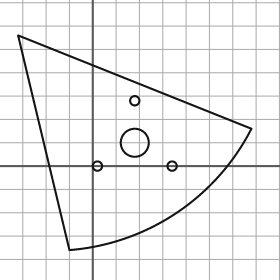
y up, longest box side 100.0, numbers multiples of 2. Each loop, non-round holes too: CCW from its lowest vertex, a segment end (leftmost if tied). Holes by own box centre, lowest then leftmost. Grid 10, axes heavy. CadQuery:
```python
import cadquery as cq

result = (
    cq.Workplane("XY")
    .moveTo(-10.0, -36.0)
    .threePointArc((36.0, -20.0), (68.0, 16.0))
    .lineTo(-32.0, 56.0)
    .close()
    .moveTo(2.0, 0.0)
    .circle(2.0)
    .moveTo(34.0, 0.0)
    .circle(2.0)
    .moveTo(18.0, 10.0)
    .circle(6.0)
    .moveTo(18.0, 28.0)
    .circle(2.0)
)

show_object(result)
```